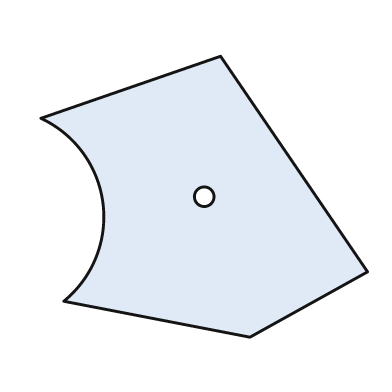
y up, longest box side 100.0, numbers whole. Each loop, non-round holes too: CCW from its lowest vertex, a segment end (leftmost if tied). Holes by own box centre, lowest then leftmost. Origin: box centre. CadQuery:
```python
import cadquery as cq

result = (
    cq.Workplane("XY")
    .moveTo(14.0, -43.0)
    .lineTo(50.0, -23.0)
    .lineTo(5.0, 43.0)
    .lineTo(-50.0, 24.0)
    .threePointArc((-31.0, -2.0), (-43.0, -32.0))
    .close()
    .moveTo(0.0, 0.0)
    .circle(3.0)
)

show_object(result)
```